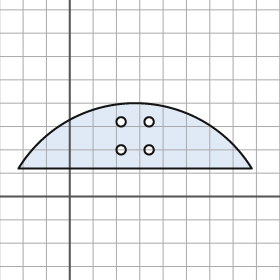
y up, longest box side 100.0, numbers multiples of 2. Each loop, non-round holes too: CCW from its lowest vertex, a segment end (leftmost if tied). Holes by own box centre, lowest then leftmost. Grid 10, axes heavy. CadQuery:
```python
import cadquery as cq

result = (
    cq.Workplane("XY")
    .moveTo(-22.0, 12.0)
    .lineTo(78.0, 12.0)
    .threePointArc((28.0, 40.0), (-22.0, 12.0))
    .close()
    .moveTo(22.0, 20.0)
    .circle(2.0)
    .moveTo(34.0, 20.0)
    .circle(2.0)
    .moveTo(22.0, 32.0)
    .circle(2.0)
    .moveTo(34.0, 32.0)
    .circle(2.0)
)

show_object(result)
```